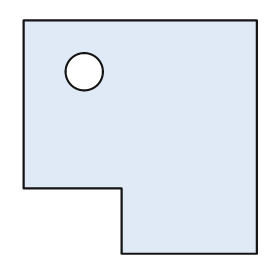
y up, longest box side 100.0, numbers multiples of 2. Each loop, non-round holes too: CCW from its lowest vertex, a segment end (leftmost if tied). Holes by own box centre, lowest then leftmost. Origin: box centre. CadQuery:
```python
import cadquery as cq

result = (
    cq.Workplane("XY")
    .moveTo(-8.0, -50.0)
    .lineTo(50.0, -50.0)
    .lineTo(50.0, 50.0)
    .lineTo(-50.0, 50.0)
    .lineTo(-50.0, -22.0)
    .lineTo(-8.0, -22.0)
    .close()
    .moveTo(-24.0, 28.0)
    .circle(8.0)
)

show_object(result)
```